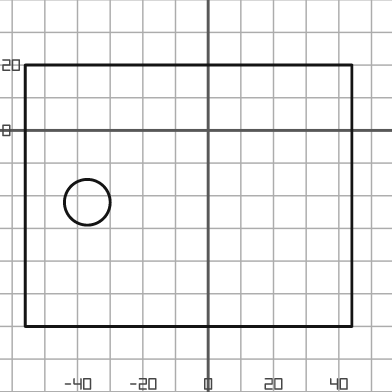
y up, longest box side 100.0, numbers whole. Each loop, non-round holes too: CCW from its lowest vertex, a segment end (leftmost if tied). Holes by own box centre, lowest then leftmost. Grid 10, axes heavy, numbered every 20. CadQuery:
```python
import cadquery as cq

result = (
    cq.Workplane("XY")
    .moveTo(-56.0, -60.0)
    .lineTo(44.0, -60.0)
    .lineTo(44.0, 20.0)
    .lineTo(-56.0, 20.0)
    .close()
    .moveTo(-37.0, -22.0)
    .circle(7.0)
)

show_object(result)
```